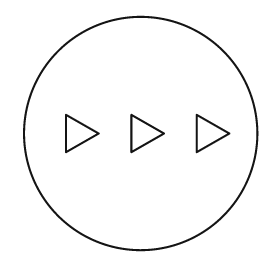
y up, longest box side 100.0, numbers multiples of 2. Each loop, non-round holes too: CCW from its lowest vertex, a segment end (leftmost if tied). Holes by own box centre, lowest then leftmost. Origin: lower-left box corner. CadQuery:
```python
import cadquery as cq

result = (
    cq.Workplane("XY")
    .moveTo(50.0, 50.0)
    .circle(50.0)
    .moveTo(18.0, 42.0)
    .lineTo(32.0, 50.0)
    .lineTo(18.0, 58.0)
    .close()
    .moveTo(46.0, 42.0)
    .lineTo(60.0, 50.0)
    .lineTo(46.0, 58.0)
    .close()
    .moveTo(74.0, 42.0)
    .lineTo(88.0, 50.0)
    .lineTo(74.0, 58.0)
    .close()
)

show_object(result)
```